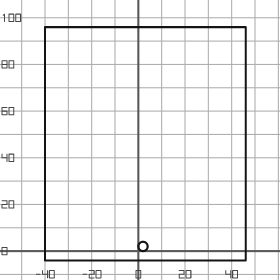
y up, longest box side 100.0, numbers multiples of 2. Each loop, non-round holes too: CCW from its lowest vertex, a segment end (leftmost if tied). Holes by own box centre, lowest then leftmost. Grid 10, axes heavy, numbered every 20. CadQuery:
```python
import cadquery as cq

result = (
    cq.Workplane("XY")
    .moveTo(-40.0, -4.0)
    .lineTo(46.0, -4.0)
    .lineTo(46.0, 96.0)
    .lineTo(-40.0, 96.0)
    .close()
    .moveTo(2.0, 2.0)
    .circle(2.0)
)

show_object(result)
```